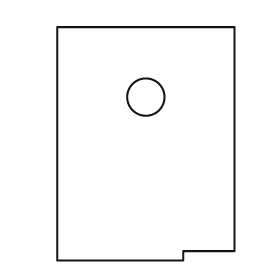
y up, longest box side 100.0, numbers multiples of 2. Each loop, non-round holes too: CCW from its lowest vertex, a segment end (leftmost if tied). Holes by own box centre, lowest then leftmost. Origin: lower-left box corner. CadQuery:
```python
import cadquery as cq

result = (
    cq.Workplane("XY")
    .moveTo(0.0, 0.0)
    .lineTo(54.0, 0.0)
    .lineTo(54.0, 4.0)
    .lineTo(76.0, 4.0)
    .lineTo(76.0, 100.0)
    .lineTo(0.0, 100.0)
    .close()
    .moveTo(38.0, 70.0)
    .circle(8.0)
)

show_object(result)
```